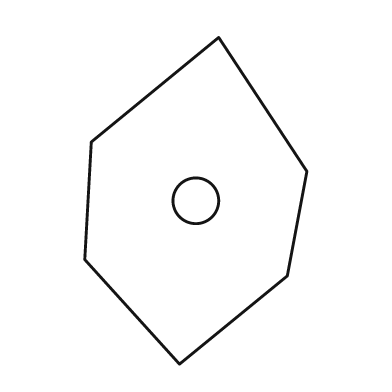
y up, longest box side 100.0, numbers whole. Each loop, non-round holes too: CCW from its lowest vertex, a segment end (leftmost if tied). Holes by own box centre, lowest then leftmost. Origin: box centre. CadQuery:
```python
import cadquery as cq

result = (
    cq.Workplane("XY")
    .moveTo(-5.0, -50.0)
    .lineTo(28.0, -23.0)
    .lineTo(34.0, 9.0)
    .lineTo(7.0, 50.0)
    .lineTo(-32.0, 18.0)
    .lineTo(-34.0, -18.0)
    .close()
    .moveTo(0.0, 0.0)
    .circle(7.0)
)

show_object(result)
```